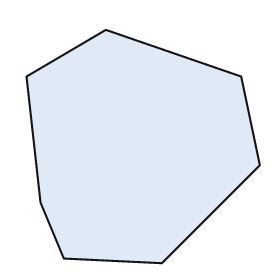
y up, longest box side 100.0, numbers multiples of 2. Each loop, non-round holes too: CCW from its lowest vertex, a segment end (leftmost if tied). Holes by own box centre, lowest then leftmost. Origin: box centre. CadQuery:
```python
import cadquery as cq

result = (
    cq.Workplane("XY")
    .moveTo(8.0, -50.0)
    .lineTo(50.0, -8.0)
    .lineTo(42.0, 30.0)
    .lineTo(-16.0, 50.0)
    .lineTo(-50.0, 30.0)
    .lineTo(-44.0, -24.0)
    .lineTo(-34.0, -48.0)
    .close()
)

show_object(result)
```